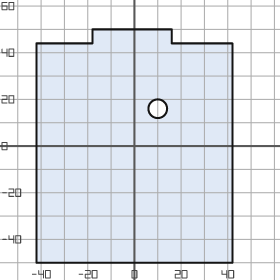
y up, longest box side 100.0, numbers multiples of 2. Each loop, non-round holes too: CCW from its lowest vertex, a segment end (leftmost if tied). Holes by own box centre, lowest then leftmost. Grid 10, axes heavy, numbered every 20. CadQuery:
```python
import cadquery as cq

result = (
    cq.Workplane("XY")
    .moveTo(-42.0, -50.0)
    .lineTo(42.0, -50.0)
    .lineTo(42.0, 44.0)
    .lineTo(16.0, 44.0)
    .lineTo(16.0, 50.0)
    .lineTo(-18.0, 50.0)
    .lineTo(-18.0, 44.0)
    .lineTo(-42.0, 44.0)
    .close()
    .moveTo(10.0, 16.0)
    .circle(4.0)
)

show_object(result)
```